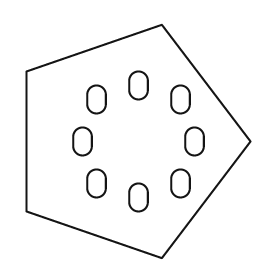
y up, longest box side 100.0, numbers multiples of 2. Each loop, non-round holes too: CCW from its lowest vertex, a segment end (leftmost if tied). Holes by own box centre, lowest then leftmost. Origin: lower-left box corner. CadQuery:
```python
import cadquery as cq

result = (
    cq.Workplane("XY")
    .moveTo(58.0, 0.0)
    .lineTo(96.0, 50.0)
    .lineTo(58.0, 100.0)
    .lineTo(0.0, 80.0)
    .lineTo(0.0, 20.0)
    .close()
    .moveTo(44.0, 24.0)
    .threePointArc((48.0, 20.0), (52.0, 24.0))
    .lineTo(52.0, 28.0)
    .threePointArc((48.0, 32.0), (44.0, 28.0))
    .close()
    .moveTo(26.0, 30.0)
    .threePointArc((30.0, 26.0), (34.0, 30.0))
    .lineTo(34.0, 34.0)
    .threePointArc((30.0, 38.0), (26.0, 34.0))
    .close()
    .moveTo(62.0, 30.0)
    .threePointArc((66.0, 26.0), (70.0, 30.0))
    .lineTo(70.0, 34.0)
    .threePointArc((66.0, 38.0), (62.0, 34.0))
    .close()
    .moveTo(20.0, 48.0)
    .threePointArc((24.0, 44.0), (28.0, 48.0))
    .lineTo(28.0, 52.0)
    .threePointArc((24.0, 56.0), (20.0, 52.0))
    .close()
    .moveTo(68.0, 48.0)
    .threePointArc((72.0, 44.0), (76.0, 48.0))
    .lineTo(76.0, 52.0)
    .threePointArc((72.0, 56.0), (68.0, 52.0))
    .close()
    .moveTo(26.0, 66.0)
    .threePointArc((30.0, 62.0), (34.0, 66.0))
    .lineTo(34.0, 70.0)
    .threePointArc((30.0, 74.0), (26.0, 70.0))
    .close()
    .moveTo(62.0, 66.0)
    .threePointArc((66.0, 62.0), (70.0, 66.0))
    .lineTo(70.0, 70.0)
    .threePointArc((66.0, 74.0), (62.0, 70.0))
    .close()
    .moveTo(44.0, 72.0)
    .threePointArc((48.0, 68.0), (52.0, 72.0))
    .lineTo(52.0, 76.0)
    .threePointArc((48.0, 80.0), (44.0, 76.0))
    .close()
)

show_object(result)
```